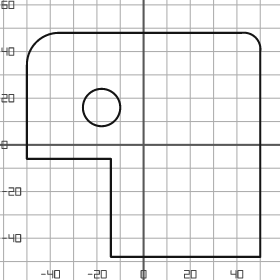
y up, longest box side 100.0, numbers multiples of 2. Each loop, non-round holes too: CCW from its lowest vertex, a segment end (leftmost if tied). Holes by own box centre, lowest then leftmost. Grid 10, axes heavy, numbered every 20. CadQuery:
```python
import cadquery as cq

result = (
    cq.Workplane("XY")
    .moveTo(-14.0, -48.0)
    .lineTo(50.0, -48.0)
    .lineTo(50.0, 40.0)
    .threePointArc((48.0, 46.0), (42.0, 48.0))
    .lineTo(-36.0, 48.0)
    .threePointArc((-46.0, 44.0), (-50.0, 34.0))
    .lineTo(-50.0, -6.0)
    .lineTo(-14.0, -6.0)
    .close()
    .moveTo(-18.0, 16.0)
    .circle(8.0)
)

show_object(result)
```